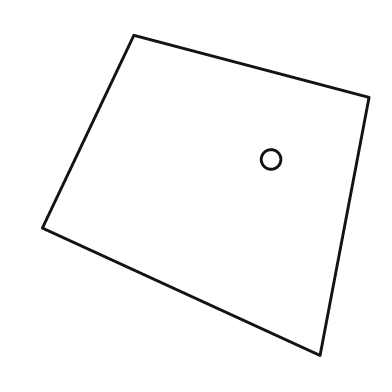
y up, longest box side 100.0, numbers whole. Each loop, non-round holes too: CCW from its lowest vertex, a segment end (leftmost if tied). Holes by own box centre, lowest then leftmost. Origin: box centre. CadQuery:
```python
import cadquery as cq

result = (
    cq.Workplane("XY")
    .moveTo(35.0, -49.0)
    .lineTo(50.0, 30.0)
    .lineTo(-22.0, 49.0)
    .lineTo(-50.0, -10.0)
    .close()
    .moveTo(20.0, 11.0)
    .circle(3.0)
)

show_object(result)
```